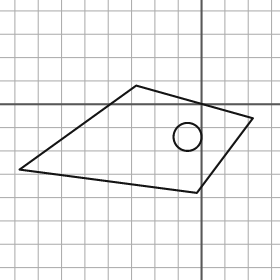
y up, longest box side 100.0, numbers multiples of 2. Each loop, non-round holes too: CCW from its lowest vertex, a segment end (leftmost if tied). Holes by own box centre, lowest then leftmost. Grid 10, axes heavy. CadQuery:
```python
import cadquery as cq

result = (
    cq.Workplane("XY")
    .moveTo(-2.0, -38.0)
    .lineTo(22.0, -6.0)
    .lineTo(-28.0, 8.0)
    .lineTo(-78.0, -28.0)
    .close()
    .moveTo(-6.0, -14.0)
    .circle(6.0)
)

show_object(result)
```